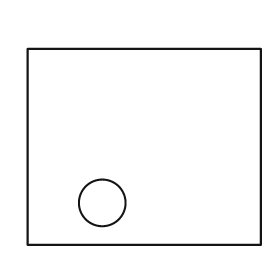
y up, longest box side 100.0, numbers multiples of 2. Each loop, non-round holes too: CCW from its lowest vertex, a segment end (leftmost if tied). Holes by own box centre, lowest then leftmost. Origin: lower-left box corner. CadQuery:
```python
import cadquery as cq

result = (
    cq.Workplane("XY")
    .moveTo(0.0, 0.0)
    .lineTo(100.0, 0.0)
    .lineTo(100.0, 84.0)
    .lineTo(0.0, 84.0)
    .close()
    .moveTo(32.0, 18.0)
    .circle(10.0)
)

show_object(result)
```